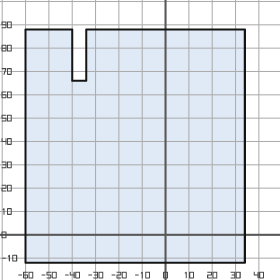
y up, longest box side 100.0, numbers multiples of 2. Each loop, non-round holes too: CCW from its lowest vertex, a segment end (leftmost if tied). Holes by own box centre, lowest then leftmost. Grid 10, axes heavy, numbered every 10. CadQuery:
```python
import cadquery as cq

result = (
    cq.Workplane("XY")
    .moveTo(-60.0, -12.0)
    .lineTo(34.0, -12.0)
    .lineTo(34.0, 88.0)
    .lineTo(-34.0, 88.0)
    .lineTo(-34.0, 66.0)
    .lineTo(-40.0, 66.0)
    .lineTo(-40.0, 88.0)
    .lineTo(-60.0, 88.0)
    .close()
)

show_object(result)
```